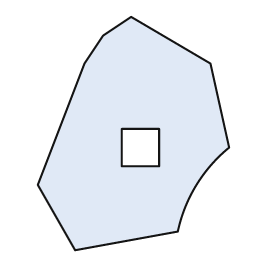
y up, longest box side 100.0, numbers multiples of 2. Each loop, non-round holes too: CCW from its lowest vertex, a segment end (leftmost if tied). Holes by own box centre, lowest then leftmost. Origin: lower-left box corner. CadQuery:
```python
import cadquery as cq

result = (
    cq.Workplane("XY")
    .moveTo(16.0, 0.0)
    .lineTo(60.0, 8.0)
    .threePointArc((68.0, 28.0), (82.0, 44.0))
    .lineTo(74.0, 80.0)
    .lineTo(40.0, 100.0)
    .lineTo(28.0, 92.0)
    .lineTo(20.0, 80.0)
    .lineTo(0.0, 28.0)
    .close()
    .moveTo(36.0, 36.0)
    .lineTo(52.0, 36.0)
    .lineTo(52.0, 52.0)
    .lineTo(36.0, 52.0)
    .close()
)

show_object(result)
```